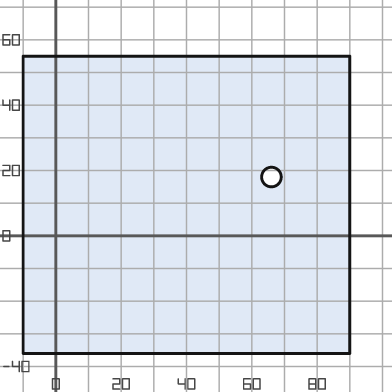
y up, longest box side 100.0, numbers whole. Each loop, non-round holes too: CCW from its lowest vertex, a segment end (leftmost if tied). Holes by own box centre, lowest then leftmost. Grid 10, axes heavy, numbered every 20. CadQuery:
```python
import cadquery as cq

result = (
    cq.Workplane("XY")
    .moveTo(-10.0, -36.0)
    .lineTo(90.0, -36.0)
    .lineTo(90.0, 55.0)
    .lineTo(-10.0, 55.0)
    .close()
    .moveTo(66.0, 18.0)
    .circle(3.0)
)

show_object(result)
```